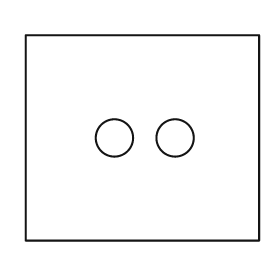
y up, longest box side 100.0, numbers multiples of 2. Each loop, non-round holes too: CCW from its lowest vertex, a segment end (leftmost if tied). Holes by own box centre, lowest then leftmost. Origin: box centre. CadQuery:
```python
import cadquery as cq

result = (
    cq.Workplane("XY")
    .moveTo(-50.0, -44.0)
    .lineTo(50.0, -44.0)
    .lineTo(50.0, 44.0)
    .lineTo(-50.0, 44.0)
    .close()
    .moveTo(-12.0, 0.0)
    .circle(8.0)
    .moveTo(14.0, 0.0)
    .circle(8.0)
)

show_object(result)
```